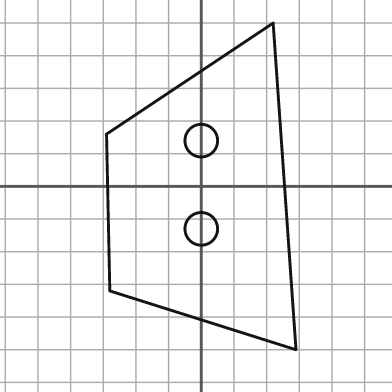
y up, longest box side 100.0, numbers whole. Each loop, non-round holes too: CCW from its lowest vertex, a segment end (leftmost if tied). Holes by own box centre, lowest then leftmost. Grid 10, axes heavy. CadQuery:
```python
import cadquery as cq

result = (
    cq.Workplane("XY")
    .moveTo(29.0, -50.0)
    .lineTo(22.0, 50.0)
    .lineTo(-29.0, 16.0)
    .lineTo(-28.0, -32.0)
    .close()
    .moveTo(0.0, -13.0)
    .circle(5.0)
    .moveTo(0.0, 14.0)
    .circle(5.0)
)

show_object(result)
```